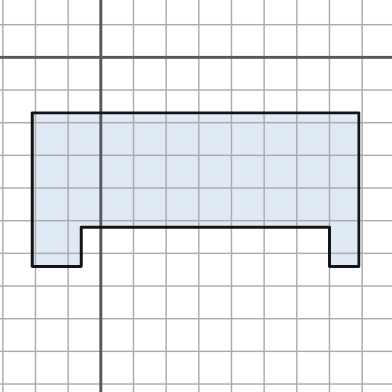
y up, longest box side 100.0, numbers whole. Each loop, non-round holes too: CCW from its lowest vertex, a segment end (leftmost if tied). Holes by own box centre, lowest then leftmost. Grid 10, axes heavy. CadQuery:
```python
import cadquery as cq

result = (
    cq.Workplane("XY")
    .moveTo(-21.0, -64.0)
    .lineTo(-6.0, -64.0)
    .lineTo(-6.0, -52.0)
    .lineTo(70.0, -52.0)
    .lineTo(70.0, -64.0)
    .lineTo(79.0, -64.0)
    .lineTo(79.0, -17.0)
    .lineTo(-21.0, -17.0)
    .close()
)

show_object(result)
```